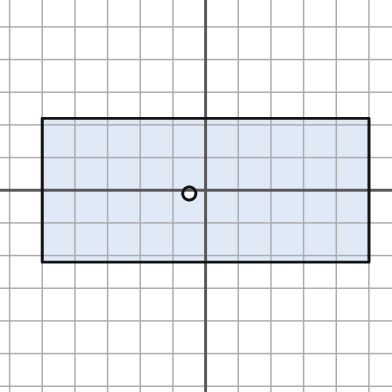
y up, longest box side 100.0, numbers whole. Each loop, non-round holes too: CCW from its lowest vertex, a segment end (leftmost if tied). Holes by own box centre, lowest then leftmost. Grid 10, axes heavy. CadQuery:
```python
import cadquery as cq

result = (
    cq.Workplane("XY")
    .moveTo(-50.0, -22.0)
    .lineTo(50.0, -22.0)
    .lineTo(50.0, 22.0)
    .lineTo(-50.0, 22.0)
    .close()
    .moveTo(-5.0, -1.0)
    .circle(2.0)
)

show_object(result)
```